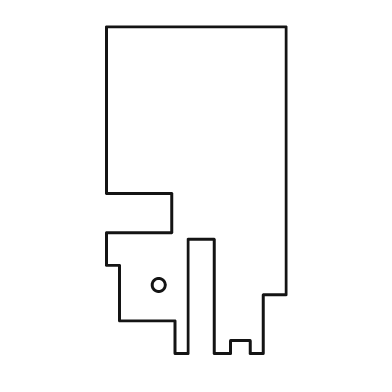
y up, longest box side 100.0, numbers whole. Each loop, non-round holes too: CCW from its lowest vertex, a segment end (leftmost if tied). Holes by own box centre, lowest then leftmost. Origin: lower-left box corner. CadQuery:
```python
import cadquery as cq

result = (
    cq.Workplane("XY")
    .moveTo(21.0, 0.0)
    .lineTo(25.0, 0.0)
    .lineTo(25.0, 35.0)
    .lineTo(33.0, 35.0)
    .lineTo(33.0, 0.0)
    .lineTo(38.0, 0.0)
    .lineTo(38.0, 4.0)
    .lineTo(44.0, 4.0)
    .lineTo(44.0, 0.0)
    .lineTo(48.0, 0.0)
    .lineTo(48.0, 18.0)
    .lineTo(55.0, 18.0)
    .lineTo(55.0, 100.0)
    .lineTo(0.0, 100.0)
    .lineTo(0.0, 49.0)
    .lineTo(20.0, 49.0)
    .lineTo(20.0, 37.0)
    .lineTo(0.0, 37.0)
    .lineTo(0.0, 27.0)
    .lineTo(4.0, 27.0)
    .lineTo(4.0, 10.0)
    .lineTo(21.0, 10.0)
    .close()
    .moveTo(16.0, 21.0)
    .circle(2.0)
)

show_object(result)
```